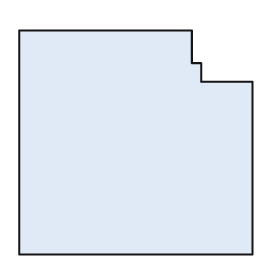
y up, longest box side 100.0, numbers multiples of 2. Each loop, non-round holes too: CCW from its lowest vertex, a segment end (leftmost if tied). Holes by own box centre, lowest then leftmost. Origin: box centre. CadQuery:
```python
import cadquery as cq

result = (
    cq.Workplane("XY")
    .moveTo(-50.0, -48.0)
    .lineTo(50.0, -48.0)
    .lineTo(50.0, 26.0)
    .lineTo(28.0, 26.0)
    .lineTo(28.0, 34.0)
    .lineTo(24.0, 34.0)
    .lineTo(24.0, 48.0)
    .lineTo(-50.0, 48.0)
    .close()
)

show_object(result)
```